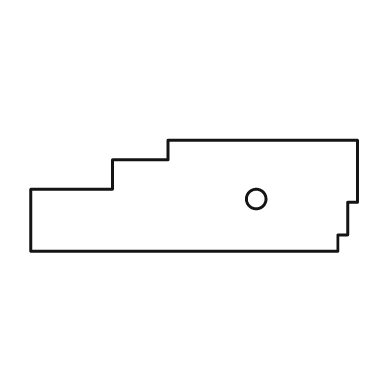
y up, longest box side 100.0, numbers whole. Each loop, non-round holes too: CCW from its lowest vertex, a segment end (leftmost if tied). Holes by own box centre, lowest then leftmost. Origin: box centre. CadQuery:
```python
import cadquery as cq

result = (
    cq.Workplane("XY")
    .moveTo(-50.0, -17.0)
    .lineTo(44.0, -17.0)
    .lineTo(44.0, -12.0)
    .lineTo(47.0, -12.0)
    .lineTo(47.0, -2.0)
    .lineTo(50.0, -2.0)
    .lineTo(50.0, 17.0)
    .lineTo(-8.0, 17.0)
    .lineTo(-8.0, 11.0)
    .lineTo(-25.0, 11.0)
    .lineTo(-25.0, 2.0)
    .lineTo(-50.0, 2.0)
    .close()
    .moveTo(19.0, -1.0)
    .circle(3.0)
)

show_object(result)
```